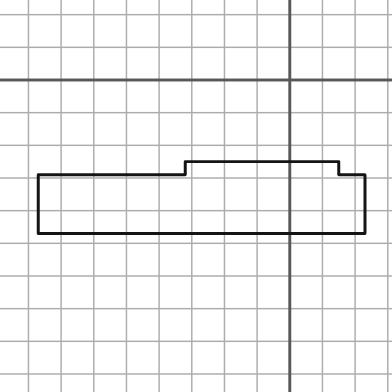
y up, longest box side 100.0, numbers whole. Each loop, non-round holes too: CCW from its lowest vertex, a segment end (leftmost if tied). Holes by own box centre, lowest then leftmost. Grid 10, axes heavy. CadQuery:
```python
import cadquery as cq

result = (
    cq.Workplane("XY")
    .moveTo(-77.0, -47.0)
    .lineTo(23.0, -47.0)
    .lineTo(23.0, -29.0)
    .lineTo(15.0, -29.0)
    .lineTo(15.0, -25.0)
    .lineTo(-32.0, -25.0)
    .lineTo(-32.0, -29.0)
    .lineTo(-77.0, -29.0)
    .close()
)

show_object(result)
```